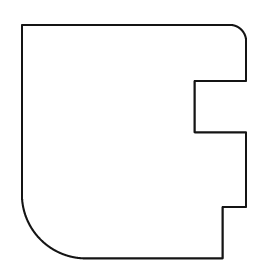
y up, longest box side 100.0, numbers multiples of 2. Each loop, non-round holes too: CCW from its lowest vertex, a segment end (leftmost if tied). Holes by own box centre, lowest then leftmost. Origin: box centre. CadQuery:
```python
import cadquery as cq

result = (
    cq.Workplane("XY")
    .moveTo(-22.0, -50.0)
    .lineTo(38.0, -50.0)
    .lineTo(38.0, -28.0)
    .lineTo(48.0, -28.0)
    .lineTo(48.0, 4.0)
    .lineTo(26.0, 4.0)
    .lineTo(26.0, 26.0)
    .lineTo(48.0, 26.0)
    .lineTo(48.0, 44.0)
    .threePointArc((46.0, 48.0), (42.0, 50.0))
    .lineTo(-48.0, 50.0)
    .lineTo(-48.0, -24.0)
    .threePointArc((-40.0, -42.0), (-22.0, -50.0))
    .close()
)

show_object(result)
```